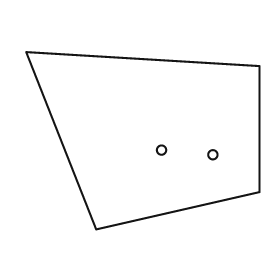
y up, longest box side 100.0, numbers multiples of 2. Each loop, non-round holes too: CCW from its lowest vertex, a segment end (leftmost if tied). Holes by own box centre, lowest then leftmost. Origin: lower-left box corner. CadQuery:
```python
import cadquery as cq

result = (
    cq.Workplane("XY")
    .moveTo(30.0, 0.0)
    .lineTo(100.0, 16.0)
    .lineTo(100.0, 70.0)
    .lineTo(0.0, 76.0)
    .close()
    .moveTo(80.0, 32.0)
    .circle(2.0)
    .moveTo(58.0, 34.0)
    .circle(2.0)
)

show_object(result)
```